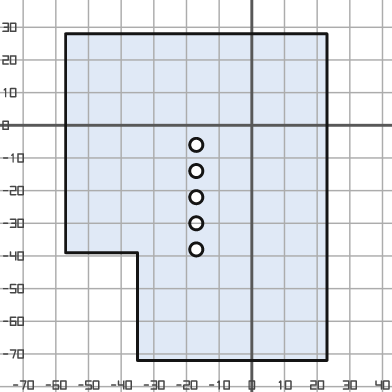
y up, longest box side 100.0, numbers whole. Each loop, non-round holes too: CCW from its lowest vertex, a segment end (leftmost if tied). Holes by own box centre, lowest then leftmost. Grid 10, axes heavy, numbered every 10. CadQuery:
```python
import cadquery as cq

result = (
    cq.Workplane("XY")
    .moveTo(-35.0, -72.0)
    .lineTo(23.0, -72.0)
    .lineTo(23.0, 28.0)
    .lineTo(-57.0, 28.0)
    .lineTo(-57.0, -39.0)
    .lineTo(-35.0, -39.0)
    .close()
    .moveTo(-17.0, -38.0)
    .circle(2.0)
    .moveTo(-17.0, -30.0)
    .circle(2.0)
    .moveTo(-17.0, -22.0)
    .circle(2.0)
    .moveTo(-17.0, -14.0)
    .circle(2.0)
    .moveTo(-17.0, -6.0)
    .circle(2.0)
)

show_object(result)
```